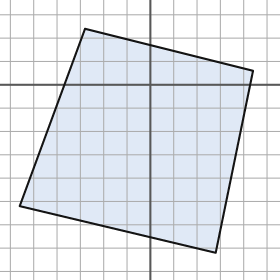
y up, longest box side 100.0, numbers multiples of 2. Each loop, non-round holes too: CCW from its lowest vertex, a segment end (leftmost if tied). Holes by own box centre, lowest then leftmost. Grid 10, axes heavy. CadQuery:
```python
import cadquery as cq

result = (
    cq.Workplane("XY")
    .moveTo(28.0, -72.0)
    .lineTo(44.0, 6.0)
    .lineTo(-28.0, 24.0)
    .lineTo(-56.0, -52.0)
    .close()
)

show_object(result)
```